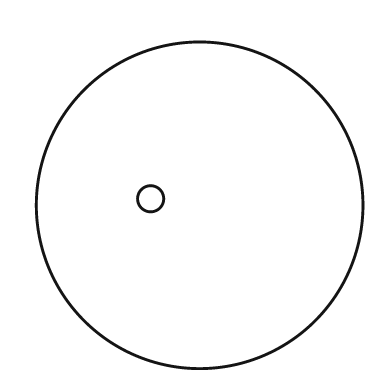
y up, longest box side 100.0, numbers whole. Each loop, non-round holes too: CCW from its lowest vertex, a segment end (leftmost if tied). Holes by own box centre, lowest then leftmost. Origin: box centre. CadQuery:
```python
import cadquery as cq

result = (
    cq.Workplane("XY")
    .moveTo(0.0, 0.0)
    .circle(50.0)
    .moveTo(-15.0, 2.0)
    .circle(4.0)
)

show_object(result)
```